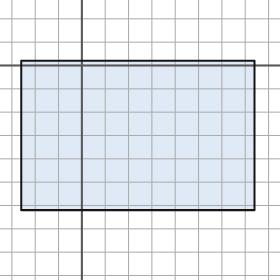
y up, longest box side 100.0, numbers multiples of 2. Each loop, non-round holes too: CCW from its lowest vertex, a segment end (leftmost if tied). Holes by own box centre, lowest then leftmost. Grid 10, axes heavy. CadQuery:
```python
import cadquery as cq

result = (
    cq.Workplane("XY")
    .moveTo(-26.0, -62.0)
    .lineTo(74.0, -62.0)
    .lineTo(74.0, 2.0)
    .lineTo(-26.0, 2.0)
    .close()
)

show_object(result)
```